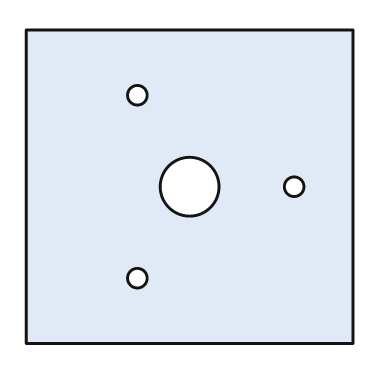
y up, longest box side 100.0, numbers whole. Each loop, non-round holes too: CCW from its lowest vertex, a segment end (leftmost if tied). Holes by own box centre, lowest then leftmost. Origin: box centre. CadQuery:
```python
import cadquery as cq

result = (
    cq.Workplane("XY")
    .moveTo(-50.0, -48.0)
    .lineTo(50.0, -48.0)
    .lineTo(50.0, 48.0)
    .lineTo(-50.0, 48.0)
    .close()
    .moveTo(-16.0, -28.0)
    .circle(3.0)
    .moveTo(0.0, 0.0)
    .circle(9.0)
    .moveTo(32.0, 0.0)
    .circle(3.0)
    .moveTo(-16.0, 28.0)
    .circle(3.0)
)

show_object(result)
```